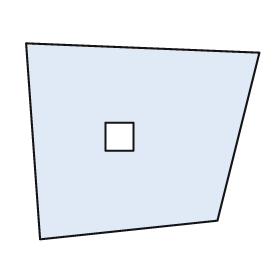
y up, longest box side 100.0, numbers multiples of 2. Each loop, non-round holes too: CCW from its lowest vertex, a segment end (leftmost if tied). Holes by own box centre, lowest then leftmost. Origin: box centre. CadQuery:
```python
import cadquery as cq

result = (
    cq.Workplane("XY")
    .moveTo(-44.0, -42.0)
    .lineTo(32.0, -34.0)
    .lineTo(50.0, 38.0)
    .lineTo(-50.0, 42.0)
    .close()
    .moveTo(-16.0, -4.0)
    .lineTo(-4.0, -4.0)
    .lineTo(-4.0, 8.0)
    .lineTo(-16.0, 8.0)
    .close()
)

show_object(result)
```